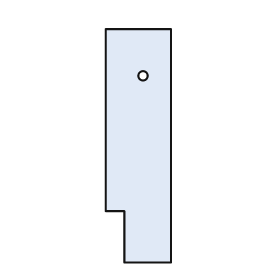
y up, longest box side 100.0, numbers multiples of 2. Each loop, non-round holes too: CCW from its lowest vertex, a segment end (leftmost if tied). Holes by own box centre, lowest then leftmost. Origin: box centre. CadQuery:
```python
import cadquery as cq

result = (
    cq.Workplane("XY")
    .moveTo(-6.0, -50.0)
    .lineTo(14.0, -50.0)
    .lineTo(14.0, 50.0)
    .lineTo(-14.0, 50.0)
    .lineTo(-14.0, -28.0)
    .lineTo(-6.0, -28.0)
    .close()
    .moveTo(2.0, 30.0)
    .circle(2.0)
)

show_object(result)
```